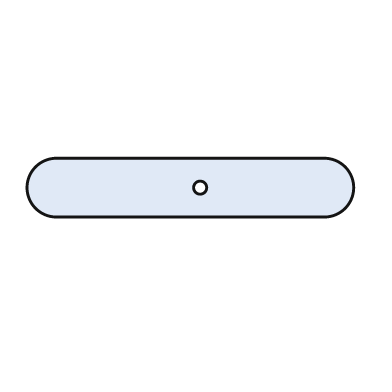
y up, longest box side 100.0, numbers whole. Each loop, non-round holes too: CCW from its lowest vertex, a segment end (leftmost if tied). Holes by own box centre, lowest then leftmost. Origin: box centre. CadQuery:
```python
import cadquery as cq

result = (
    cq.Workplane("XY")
    .moveTo(-41.0, -9.0)
    .lineTo(41.0, -9.0)
    .threePointArc((50.0, 0.0), (41.0, 9.0))
    .lineTo(-41.0, 9.0)
    .threePointArc((-50.0, 0.0), (-41.0, -9.0))
    .close()
    .moveTo(3.0, 0.0)
    .circle(2.0)
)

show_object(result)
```